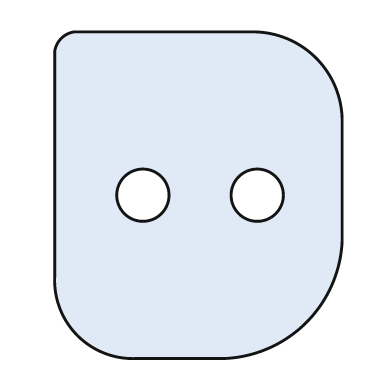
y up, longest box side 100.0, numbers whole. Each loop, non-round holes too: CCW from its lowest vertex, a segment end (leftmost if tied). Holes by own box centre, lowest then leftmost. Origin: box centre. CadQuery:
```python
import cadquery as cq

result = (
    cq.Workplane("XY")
    .moveTo(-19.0, -50.0)
    .lineTo(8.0, -50.0)
    .threePointArc((33.0, -39.0), (44.0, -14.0))
    .lineTo(44.0, 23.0)
    .threePointArc((36.0, 42.0), (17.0, 50.0))
    .lineTo(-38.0, 50.0)
    .threePointArc((-42.0, 48.0), (-44.0, 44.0))
    .lineTo(-44.0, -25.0)
    .threePointArc((-37.0, -43.0), (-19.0, -50.0))
    .close()
    .moveTo(-17.0, 0.0)
    .circle(8.0)
    .moveTo(18.0, 0.0)
    .circle(8.0)
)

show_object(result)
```